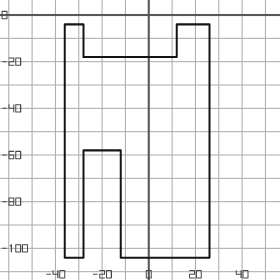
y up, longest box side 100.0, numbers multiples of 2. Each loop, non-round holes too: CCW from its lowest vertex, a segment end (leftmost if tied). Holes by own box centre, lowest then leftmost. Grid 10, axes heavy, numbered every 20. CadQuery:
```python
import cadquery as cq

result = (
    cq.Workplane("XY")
    .moveTo(-36.0, -104.0)
    .lineTo(-28.0, -104.0)
    .lineTo(-28.0, -58.0)
    .lineTo(-12.0, -58.0)
    .lineTo(-12.0, -104.0)
    .lineTo(26.0, -104.0)
    .lineTo(26.0, -4.0)
    .lineTo(12.0, -4.0)
    .lineTo(12.0, -18.0)
    .lineTo(-28.0, -18.0)
    .lineTo(-28.0, -4.0)
    .lineTo(-36.0, -4.0)
    .close()
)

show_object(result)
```